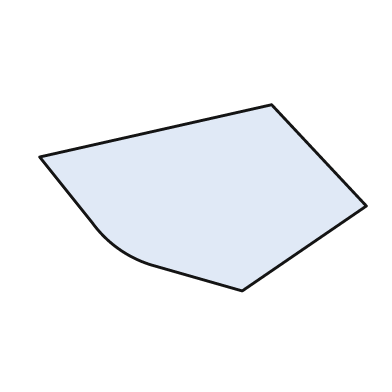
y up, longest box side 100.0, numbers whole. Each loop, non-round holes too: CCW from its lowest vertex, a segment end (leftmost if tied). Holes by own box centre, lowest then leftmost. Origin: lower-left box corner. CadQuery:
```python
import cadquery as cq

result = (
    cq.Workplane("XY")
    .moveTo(62.0, 0.0)
    .lineTo(100.0, 26.0)
    .lineTo(71.0, 57.0)
    .lineTo(0.0, 41.0)
    .lineTo(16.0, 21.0)
    .threePointArc((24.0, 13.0), (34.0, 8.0))
    .close()
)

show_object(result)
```